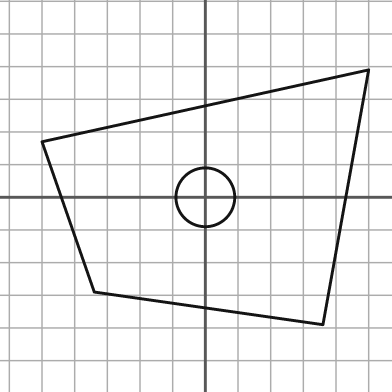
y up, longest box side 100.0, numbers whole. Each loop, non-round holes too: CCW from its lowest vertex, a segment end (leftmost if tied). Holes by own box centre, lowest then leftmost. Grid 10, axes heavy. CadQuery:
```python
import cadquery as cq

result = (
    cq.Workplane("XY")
    .moveTo(36.0, -39.0)
    .lineTo(50.0, 39.0)
    .lineTo(-50.0, 17.0)
    .lineTo(-34.0, -29.0)
    .close()
    .moveTo(0.0, 0.0)
    .circle(9.0)
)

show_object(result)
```